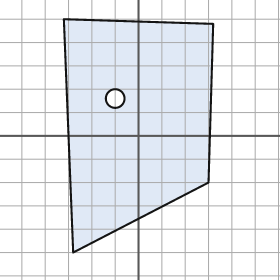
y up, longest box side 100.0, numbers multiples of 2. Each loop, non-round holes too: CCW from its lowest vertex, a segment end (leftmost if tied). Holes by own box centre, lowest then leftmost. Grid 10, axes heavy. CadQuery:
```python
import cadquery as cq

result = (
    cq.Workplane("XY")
    .moveTo(-28.0, -50.0)
    .lineTo(30.0, -20.0)
    .lineTo(32.0, 48.0)
    .lineTo(-32.0, 50.0)
    .close()
    .moveTo(-10.0, 16.0)
    .circle(4.0)
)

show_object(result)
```